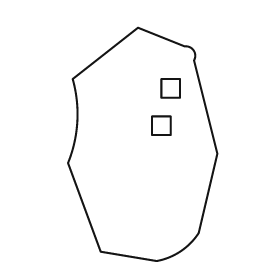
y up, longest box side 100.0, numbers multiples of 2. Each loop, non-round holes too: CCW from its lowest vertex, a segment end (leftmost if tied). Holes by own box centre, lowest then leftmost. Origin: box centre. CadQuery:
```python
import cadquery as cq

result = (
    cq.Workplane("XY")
    .moveTo(6.0, -50.0)
    .threePointArc((16.0, -46.0), (24.0, -38.0))
    .lineTo(32.0, -4.0)
    .lineTo(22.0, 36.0)
    .threePointArc((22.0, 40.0), (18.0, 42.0))
    .lineTo(-2.0, 50.0)
    .lineTo(-30.0, 28.0)
    .threePointArc((-28.0, 10.0), (-32.0, -8.0))
    .lineTo(-18.0, -46.0)
    .close()
    .moveTo(4.0, 4.0)
    .lineTo(12.0, 4.0)
    .lineTo(12.0, 12.0)
    .lineTo(4.0, 12.0)
    .close()
    .moveTo(8.0, 20.0)
    .lineTo(16.0, 20.0)
    .lineTo(16.0, 28.0)
    .lineTo(8.0, 28.0)
    .close()
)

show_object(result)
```